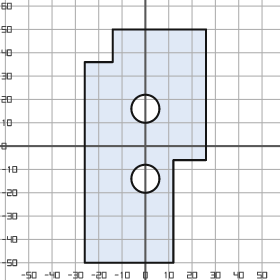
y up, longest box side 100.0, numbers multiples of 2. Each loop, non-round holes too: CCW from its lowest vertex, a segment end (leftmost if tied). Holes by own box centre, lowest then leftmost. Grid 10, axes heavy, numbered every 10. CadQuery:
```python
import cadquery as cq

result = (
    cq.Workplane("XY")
    .moveTo(-26.0, -50.0)
    .lineTo(12.0, -50.0)
    .lineTo(12.0, -6.0)
    .lineTo(26.0, -6.0)
    .lineTo(26.0, 50.0)
    .lineTo(-14.0, 50.0)
    .lineTo(-14.0, 36.0)
    .lineTo(-26.0, 36.0)
    .close()
    .moveTo(0.0, -14.0)
    .circle(6.0)
    .moveTo(0.0, 16.0)
    .circle(6.0)
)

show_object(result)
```